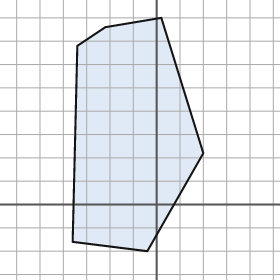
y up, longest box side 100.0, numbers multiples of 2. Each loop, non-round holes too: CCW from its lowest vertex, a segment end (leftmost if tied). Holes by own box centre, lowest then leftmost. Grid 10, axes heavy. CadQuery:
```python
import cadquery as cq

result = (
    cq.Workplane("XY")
    .moveTo(-4.0, -20.0)
    .lineTo(20.0, 22.0)
    .lineTo(2.0, 80.0)
    .lineTo(-22.0, 76.0)
    .lineTo(-34.0, 68.0)
    .lineTo(-36.0, -16.0)
    .close()
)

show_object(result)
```